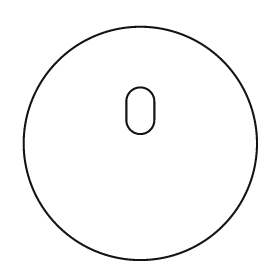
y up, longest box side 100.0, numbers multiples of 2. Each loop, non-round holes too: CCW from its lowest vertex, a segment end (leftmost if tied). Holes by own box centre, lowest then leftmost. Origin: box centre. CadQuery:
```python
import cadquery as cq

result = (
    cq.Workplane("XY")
    .moveTo(0.0, 0.0)
    .circle(50.0)
    .moveTo(-6.0, 10.0)
    .threePointArc((0.0, 4.0), (6.0, 10.0))
    .lineTo(6.0, 18.0)
    .threePointArc((0.0, 24.0), (-6.0, 18.0))
    .close()
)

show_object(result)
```